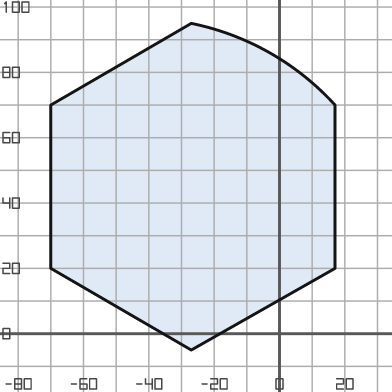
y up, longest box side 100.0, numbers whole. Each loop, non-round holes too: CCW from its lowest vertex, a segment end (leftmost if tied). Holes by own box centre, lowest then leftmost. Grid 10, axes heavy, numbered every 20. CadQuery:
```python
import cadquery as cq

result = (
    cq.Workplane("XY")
    .moveTo(-27.0, -5.0)
    .lineTo(17.0, 20.0)
    .lineTo(17.0, 70.0)
    .threePointArc((-3.0, 86.0), (-27.0, 95.0))
    .lineTo(-70.0, 70.0)
    .lineTo(-70.0, 20.0)
    .close()
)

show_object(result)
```